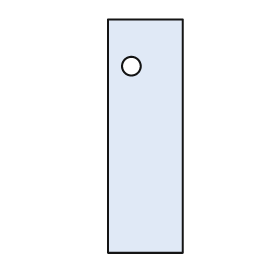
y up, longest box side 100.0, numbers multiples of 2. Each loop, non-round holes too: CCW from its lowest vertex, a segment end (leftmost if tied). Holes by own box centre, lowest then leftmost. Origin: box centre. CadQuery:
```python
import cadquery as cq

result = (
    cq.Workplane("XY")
    .moveTo(-16.0, -50.0)
    .lineTo(16.0, -50.0)
    .lineTo(16.0, 50.0)
    .lineTo(-16.0, 50.0)
    .close()
    .moveTo(-6.0, 30.0)
    .circle(4.0)
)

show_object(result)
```